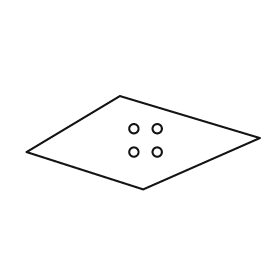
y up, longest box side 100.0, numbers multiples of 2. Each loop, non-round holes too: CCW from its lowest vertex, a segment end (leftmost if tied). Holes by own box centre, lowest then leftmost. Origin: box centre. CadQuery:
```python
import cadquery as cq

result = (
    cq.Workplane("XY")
    .moveTo(0.0, -20.0)
    .lineTo(50.0, 2.0)
    .lineTo(-10.0, 20.0)
    .lineTo(-50.0, -4.0)
    .close()
    .moveTo(-4.0, -4.0)
    .circle(2.0)
    .moveTo(6.0, -4.0)
    .circle(2.0)
    .moveTo(-4.0, 6.0)
    .circle(2.0)
    .moveTo(6.0, 6.0)
    .circle(2.0)
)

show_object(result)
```